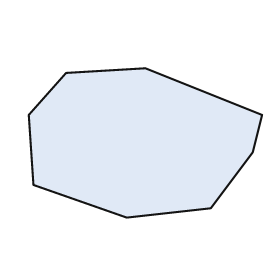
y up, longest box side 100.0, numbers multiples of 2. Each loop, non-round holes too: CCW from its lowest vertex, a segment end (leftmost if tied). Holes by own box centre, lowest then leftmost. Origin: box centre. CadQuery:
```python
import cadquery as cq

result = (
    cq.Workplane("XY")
    .moveTo(-8.0, -32.0)
    .lineTo(28.0, -28.0)
    .lineTo(46.0, -4.0)
    .lineTo(50.0, 12.0)
    .lineTo(0.0, 32.0)
    .lineTo(-34.0, 30.0)
    .lineTo(-50.0, 12.0)
    .lineTo(-48.0, -18.0)
    .close()
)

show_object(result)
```